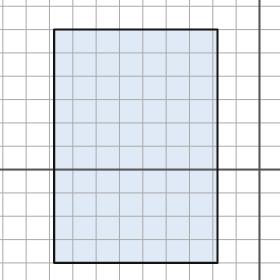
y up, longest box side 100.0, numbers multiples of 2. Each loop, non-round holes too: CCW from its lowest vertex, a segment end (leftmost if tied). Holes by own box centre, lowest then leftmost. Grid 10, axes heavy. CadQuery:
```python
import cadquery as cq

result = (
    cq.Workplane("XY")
    .moveTo(-88.0, -40.0)
    .lineTo(-18.0, -40.0)
    .lineTo(-18.0, 60.0)
    .lineTo(-88.0, 60.0)
    .close()
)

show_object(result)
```